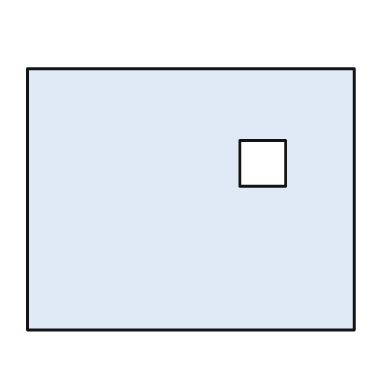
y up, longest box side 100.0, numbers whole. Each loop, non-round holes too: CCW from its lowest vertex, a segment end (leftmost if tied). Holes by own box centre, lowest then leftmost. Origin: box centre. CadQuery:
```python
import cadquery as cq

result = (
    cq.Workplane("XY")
    .moveTo(-50.0, -40.0)
    .lineTo(50.0, -40.0)
    .lineTo(50.0, 40.0)
    .lineTo(-50.0, 40.0)
    .close()
    .moveTo(15.0, 4.0)
    .lineTo(29.0, 4.0)
    .lineTo(29.0, 18.0)
    .lineTo(15.0, 18.0)
    .close()
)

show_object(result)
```